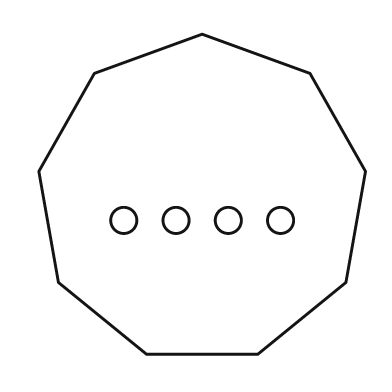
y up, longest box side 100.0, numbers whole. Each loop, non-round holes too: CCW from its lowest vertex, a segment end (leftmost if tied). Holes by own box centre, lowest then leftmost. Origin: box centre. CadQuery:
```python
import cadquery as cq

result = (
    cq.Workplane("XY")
    .moveTo(-17.0, -49.0)
    .lineTo(17.0, -49.0)
    .lineTo(44.0, -27.0)
    .lineTo(50.0, 7.0)
    .lineTo(33.0, 37.0)
    .lineTo(0.0, 49.0)
    .lineTo(-33.0, 37.0)
    .lineTo(-50.0, 7.0)
    .lineTo(-44.0, -27.0)
    .close()
    .moveTo(-24.0, -8.0)
    .circle(4.0)
    .moveTo(-8.0, -8.0)
    .circle(4.0)
    .moveTo(8.0, -8.0)
    .circle(4.0)
    .moveTo(24.0, -8.0)
    .circle(4.0)
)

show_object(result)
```